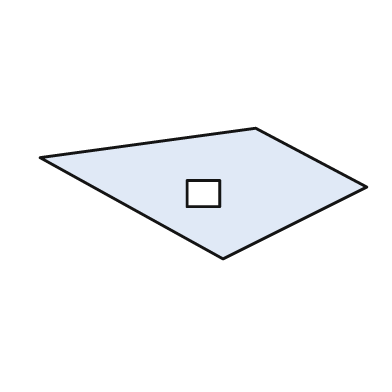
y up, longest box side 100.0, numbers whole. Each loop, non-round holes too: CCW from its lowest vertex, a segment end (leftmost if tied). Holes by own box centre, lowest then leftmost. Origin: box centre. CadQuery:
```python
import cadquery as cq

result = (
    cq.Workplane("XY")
    .moveTo(6.0, -20.0)
    .lineTo(50.0, 2.0)
    .lineTo(16.0, 20.0)
    .lineTo(-50.0, 11.0)
    .close()
    .moveTo(-5.0, -4.0)
    .lineTo(5.0, -4.0)
    .lineTo(5.0, 4.0)
    .lineTo(-5.0, 4.0)
    .close()
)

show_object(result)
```